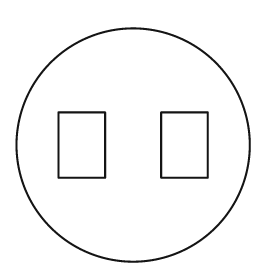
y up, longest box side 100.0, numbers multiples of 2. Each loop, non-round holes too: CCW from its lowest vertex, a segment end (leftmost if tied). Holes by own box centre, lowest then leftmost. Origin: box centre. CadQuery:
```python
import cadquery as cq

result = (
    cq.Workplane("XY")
    .moveTo(0.0, 0.0)
    .circle(50.0)
    .moveTo(-32.0, -14.0)
    .lineTo(-12.0, -14.0)
    .lineTo(-12.0, 14.0)
    .lineTo(-32.0, 14.0)
    .close()
    .moveTo(12.0, -14.0)
    .lineTo(32.0, -14.0)
    .lineTo(32.0, 14.0)
    .lineTo(12.0, 14.0)
    .close()
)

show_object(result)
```